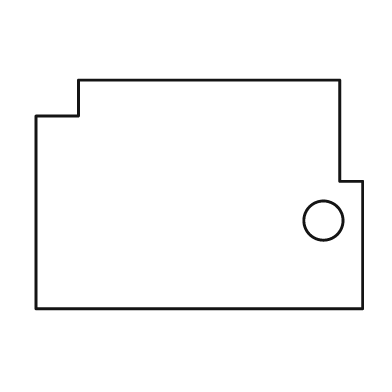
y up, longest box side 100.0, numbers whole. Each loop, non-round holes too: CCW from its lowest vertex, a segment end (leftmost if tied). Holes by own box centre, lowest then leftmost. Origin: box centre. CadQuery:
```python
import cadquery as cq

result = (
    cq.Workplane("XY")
    .moveTo(-50.0, -35.0)
    .lineTo(50.0, -35.0)
    .lineTo(50.0, 4.0)
    .lineTo(43.0, 4.0)
    .lineTo(43.0, 35.0)
    .lineTo(-37.0, 35.0)
    .lineTo(-37.0, 24.0)
    .lineTo(-50.0, 24.0)
    .close()
    .moveTo(38.0, -8.0)
    .circle(6.0)
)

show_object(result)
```